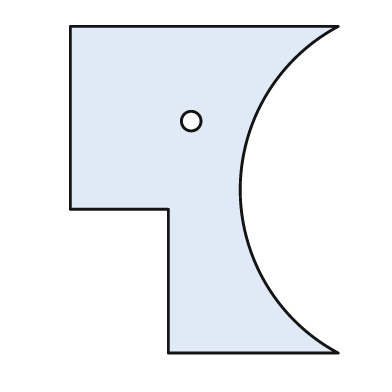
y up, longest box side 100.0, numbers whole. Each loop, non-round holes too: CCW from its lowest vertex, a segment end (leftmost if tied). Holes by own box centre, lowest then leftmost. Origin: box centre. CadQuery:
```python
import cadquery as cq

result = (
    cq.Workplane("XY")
    .moveTo(-11.0, -50.0)
    .lineTo(41.0, -50.0)
    .threePointArc((11.0, 0.0), (41.0, 50.0))
    .lineTo(-41.0, 50.0)
    .lineTo(-41.0, -6.0)
    .lineTo(-11.0, -6.0)
    .close()
    .moveTo(-4.0, 21.0)
    .circle(3.0)
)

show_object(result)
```